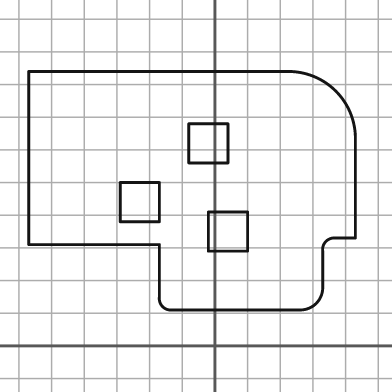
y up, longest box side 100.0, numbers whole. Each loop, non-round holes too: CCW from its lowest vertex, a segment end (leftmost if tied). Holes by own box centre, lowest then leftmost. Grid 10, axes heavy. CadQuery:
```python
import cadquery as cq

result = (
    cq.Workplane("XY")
    .moveTo(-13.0, 11.0)
    .lineTo(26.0, 11.0)
    .threePointArc((31.0, 13.0), (33.0, 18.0))
    .lineTo(33.0, 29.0)
    .threePointArc((34.0, 32.0), (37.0, 33.0))
    .lineTo(43.0, 33.0)
    .lineTo(43.0, 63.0)
    .threePointArc((37.0, 78.0), (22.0, 84.0))
    .lineTo(-57.0, 84.0)
    .lineTo(-57.0, 31.0)
    .lineTo(-17.0, 31.0)
    .lineTo(-17.0, 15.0)
    .threePointArc((-16.0, 12.0), (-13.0, 11.0))
    .close()
    .moveTo(-2.0, 29.0)
    .lineTo(10.0, 29.0)
    .lineTo(10.0, 41.0)
    .lineTo(-2.0, 41.0)
    .close()
    .moveTo(-29.0, 38.0)
    .lineTo(-17.0, 38.0)
    .lineTo(-17.0, 50.0)
    .lineTo(-29.0, 50.0)
    .close()
    .moveTo(-8.0, 56.0)
    .lineTo(4.0, 56.0)
    .lineTo(4.0, 68.0)
    .lineTo(-8.0, 68.0)
    .close()
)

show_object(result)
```